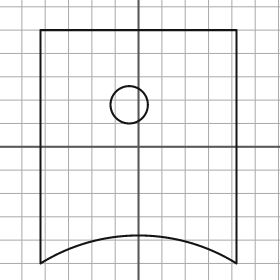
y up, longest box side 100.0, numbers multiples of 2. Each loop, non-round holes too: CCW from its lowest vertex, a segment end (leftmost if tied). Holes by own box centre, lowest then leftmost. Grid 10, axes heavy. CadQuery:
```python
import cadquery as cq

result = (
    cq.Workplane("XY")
    .moveTo(-42.0, -50.0)
    .threePointArc((0.0, -38.0), (42.0, -50.0))
    .lineTo(42.0, 50.0)
    .lineTo(-42.0, 50.0)
    .close()
    .moveTo(-4.0, 18.0)
    .circle(8.0)
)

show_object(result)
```